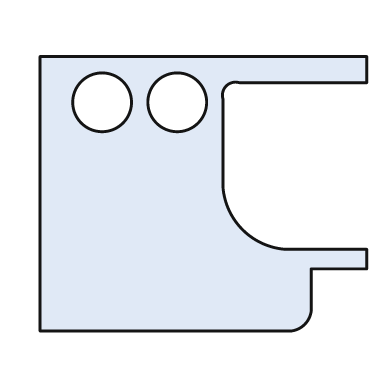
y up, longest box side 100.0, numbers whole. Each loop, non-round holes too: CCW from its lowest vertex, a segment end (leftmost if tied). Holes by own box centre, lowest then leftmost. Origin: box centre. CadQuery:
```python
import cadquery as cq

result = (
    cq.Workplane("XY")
    .moveTo(-50.0, -42.0)
    .lineTo(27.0, -42.0)
    .threePointArc((31.0, -40.0), (33.0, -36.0))
    .lineTo(33.0, -23.0)
    .lineTo(50.0, -23.0)
    .lineTo(50.0, -17.0)
    .lineTo(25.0, -17.0)
    .threePointArc((12.0, -11.0), (6.0, 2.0))
    .lineTo(6.0, 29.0)
    .threePointArc((7.0, 33.0), (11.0, 34.0))
    .lineTo(50.0, 34.0)
    .lineTo(50.0, 42.0)
    .lineTo(-50.0, 42.0)
    .close()
    .moveTo(-31.0, 28.0)
    .circle(9.0)
    .moveTo(-8.0, 28.0)
    .circle(9.0)
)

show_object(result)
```